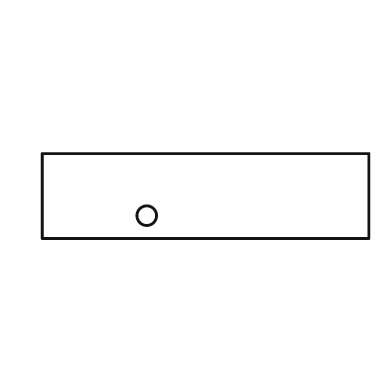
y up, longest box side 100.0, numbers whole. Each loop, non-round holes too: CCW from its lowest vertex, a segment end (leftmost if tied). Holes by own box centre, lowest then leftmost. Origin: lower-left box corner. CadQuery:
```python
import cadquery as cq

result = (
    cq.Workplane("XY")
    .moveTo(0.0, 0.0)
    .lineTo(100.0, 0.0)
    .lineTo(100.0, 26.0)
    .lineTo(0.0, 26.0)
    .close()
    .moveTo(32.0, 7.0)
    .circle(3.0)
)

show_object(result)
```